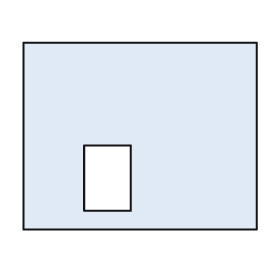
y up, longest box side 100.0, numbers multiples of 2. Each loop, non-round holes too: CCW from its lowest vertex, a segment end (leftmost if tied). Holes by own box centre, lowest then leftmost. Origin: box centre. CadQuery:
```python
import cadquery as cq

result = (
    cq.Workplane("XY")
    .moveTo(-50.0, -40.0)
    .lineTo(50.0, -40.0)
    .lineTo(50.0, 40.0)
    .lineTo(-50.0, 40.0)
    .close()
    .moveTo(-24.0, -32.0)
    .lineTo(-4.0, -32.0)
    .lineTo(-4.0, -4.0)
    .lineTo(-24.0, -4.0)
    .close()
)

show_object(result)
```